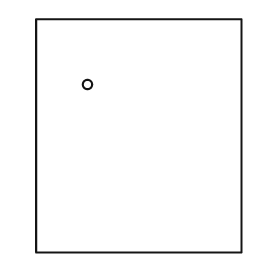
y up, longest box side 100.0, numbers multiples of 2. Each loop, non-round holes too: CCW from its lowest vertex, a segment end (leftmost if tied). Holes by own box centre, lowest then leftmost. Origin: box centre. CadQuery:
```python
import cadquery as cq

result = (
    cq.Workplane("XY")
    .moveTo(-44.0, -50.0)
    .lineTo(44.0, -50.0)
    .lineTo(44.0, 50.0)
    .lineTo(-44.0, 50.0)
    .close()
    .moveTo(-22.0, 22.0)
    .circle(2.0)
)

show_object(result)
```